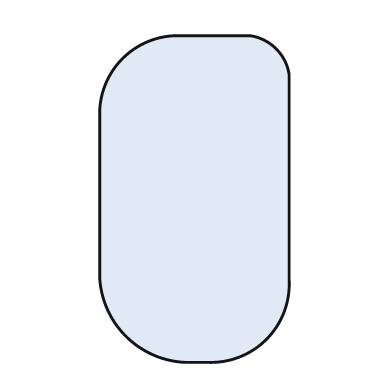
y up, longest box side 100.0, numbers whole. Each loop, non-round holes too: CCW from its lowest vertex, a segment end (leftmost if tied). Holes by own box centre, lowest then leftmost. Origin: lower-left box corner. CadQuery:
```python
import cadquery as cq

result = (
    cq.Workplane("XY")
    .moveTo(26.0, 0.0)
    .lineTo(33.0, 0.0)
    .threePointArc((51.0, 7.0), (58.0, 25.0))
    .lineTo(58.0, 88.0)
    .threePointArc((54.0, 96.0), (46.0, 100.0))
    .lineTo(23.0, 100.0)
    .threePointArc((7.0, 93.0), (0.0, 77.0))
    .lineTo(0.0, 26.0)
    .threePointArc((8.0, 8.0), (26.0, 0.0))
    .close()
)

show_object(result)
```